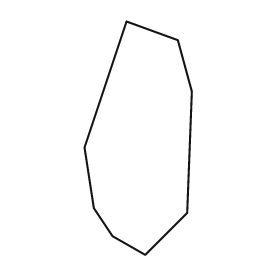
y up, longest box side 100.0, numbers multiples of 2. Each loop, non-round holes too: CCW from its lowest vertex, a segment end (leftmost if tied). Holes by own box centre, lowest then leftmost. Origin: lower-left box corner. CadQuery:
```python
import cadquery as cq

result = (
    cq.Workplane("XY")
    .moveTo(26.0, 0.0)
    .lineTo(44.0, 18.0)
    .lineTo(46.0, 70.0)
    .lineTo(40.0, 92.0)
    .lineTo(18.0, 100.0)
    .lineTo(0.0, 46.0)
    .lineTo(4.0, 20.0)
    .lineTo(12.0, 8.0)
    .close()
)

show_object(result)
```